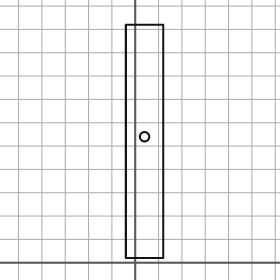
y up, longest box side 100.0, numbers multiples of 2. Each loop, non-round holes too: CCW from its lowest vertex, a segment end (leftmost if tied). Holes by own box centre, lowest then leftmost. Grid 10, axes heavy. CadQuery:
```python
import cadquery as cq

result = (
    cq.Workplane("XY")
    .moveTo(-4.0, 2.0)
    .lineTo(12.0, 2.0)
    .lineTo(12.0, 102.0)
    .lineTo(-4.0, 102.0)
    .close()
    .moveTo(4.0, 54.0)
    .circle(2.0)
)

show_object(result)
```